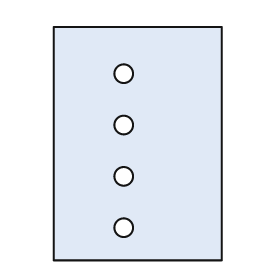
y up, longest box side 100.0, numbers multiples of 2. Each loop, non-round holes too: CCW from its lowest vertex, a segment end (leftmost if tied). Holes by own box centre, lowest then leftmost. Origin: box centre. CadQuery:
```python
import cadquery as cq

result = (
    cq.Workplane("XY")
    .moveTo(-36.0, -50.0)
    .lineTo(36.0, -50.0)
    .lineTo(36.0, 50.0)
    .lineTo(-36.0, 50.0)
    .close()
    .moveTo(-6.0, -36.0)
    .circle(4.0)
    .moveTo(-6.0, -14.0)
    .circle(4.0)
    .moveTo(-6.0, 8.0)
    .circle(4.0)
    .moveTo(-6.0, 30.0)
    .circle(4.0)
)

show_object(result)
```